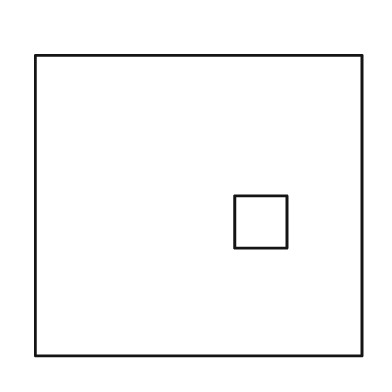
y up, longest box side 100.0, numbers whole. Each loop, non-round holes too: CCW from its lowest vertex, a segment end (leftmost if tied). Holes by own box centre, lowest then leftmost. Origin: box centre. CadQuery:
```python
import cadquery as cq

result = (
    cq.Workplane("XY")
    .moveTo(-50.0, -46.0)
    .lineTo(50.0, -46.0)
    .lineTo(50.0, 46.0)
    .lineTo(-50.0, 46.0)
    .close()
    .moveTo(11.0, -13.0)
    .lineTo(27.0, -13.0)
    .lineTo(27.0, 3.0)
    .lineTo(11.0, 3.0)
    .close()
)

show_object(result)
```